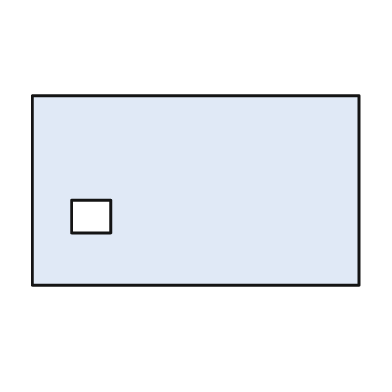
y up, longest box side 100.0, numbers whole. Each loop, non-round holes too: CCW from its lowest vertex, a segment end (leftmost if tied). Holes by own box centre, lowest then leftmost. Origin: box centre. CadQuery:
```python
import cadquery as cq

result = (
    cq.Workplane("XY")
    .moveTo(-50.0, -29.0)
    .lineTo(50.0, -29.0)
    .lineTo(50.0, 29.0)
    .lineTo(-50.0, 29.0)
    .close()
    .moveTo(-38.0, -13.0)
    .lineTo(-26.0, -13.0)
    .lineTo(-26.0, -3.0)
    .lineTo(-38.0, -3.0)
    .close()
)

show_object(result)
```